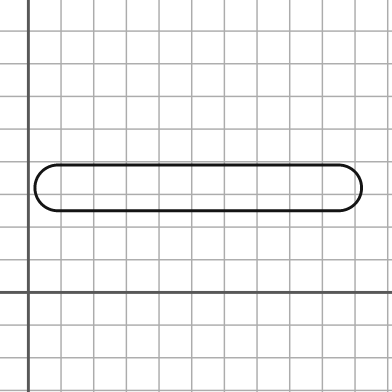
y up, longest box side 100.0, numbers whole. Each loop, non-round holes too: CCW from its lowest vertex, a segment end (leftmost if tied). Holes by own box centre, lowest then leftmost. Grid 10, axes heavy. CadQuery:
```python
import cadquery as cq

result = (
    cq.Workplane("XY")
    .moveTo(9.0, 25.0)
    .lineTo(95.0, 25.0)
    .threePointArc((102.0, 32.0), (95.0, 39.0))
    .lineTo(9.0, 39.0)
    .threePointArc((2.0, 32.0), (9.0, 25.0))
    .close()
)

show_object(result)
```